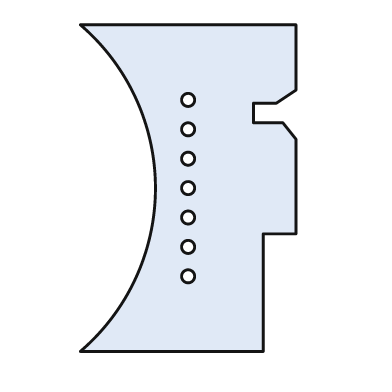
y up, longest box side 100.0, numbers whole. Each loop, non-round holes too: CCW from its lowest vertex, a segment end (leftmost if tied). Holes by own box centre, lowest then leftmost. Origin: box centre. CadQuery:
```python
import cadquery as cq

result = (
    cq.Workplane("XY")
    .moveTo(-33.0, -50.0)
    .lineTo(23.0, -50.0)
    .lineTo(23.0, -14.0)
    .lineTo(33.0, -14.0)
    .lineTo(33.0, 15.0)
    .lineTo(29.0, 20.0)
    .lineTo(20.0, 20.0)
    .lineTo(20.0, 26.0)
    .lineTo(27.0, 26.0)
    .lineTo(33.0, 30.0)
    .lineTo(33.0, 50.0)
    .lineTo(-33.0, 50.0)
    .threePointArc((-10.0, 0.0), (-33.0, -50.0))
    .close()
    .moveTo(0.0, -27.0)
    .circle(2.0)
    .moveTo(0.0, -18.0)
    .circle(2.0)
    .moveTo(0.0, -9.0)
    .circle(2.0)
    .moveTo(0.0, 0.0)
    .circle(2.0)
    .moveTo(0.0, 9.0)
    .circle(2.0)
    .moveTo(0.0, 18.0)
    .circle(2.0)
    .moveTo(0.0, 27.0)
    .circle(2.0)
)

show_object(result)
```